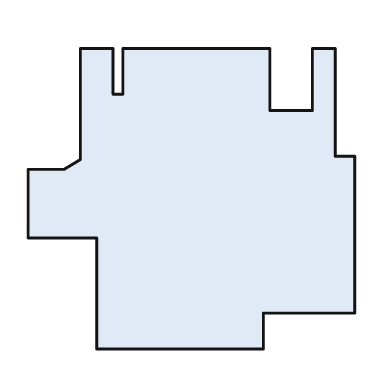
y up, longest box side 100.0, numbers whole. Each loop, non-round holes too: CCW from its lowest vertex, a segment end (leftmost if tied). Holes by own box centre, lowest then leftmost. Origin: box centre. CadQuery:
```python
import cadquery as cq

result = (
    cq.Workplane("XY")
    .moveTo(-29.0, -46.0)
    .lineTo(22.0, -46.0)
    .lineTo(22.0, -35.0)
    .lineTo(50.0, -35.0)
    .lineTo(50.0, 13.0)
    .lineTo(44.0, 13.0)
    .lineTo(44.0, 46.0)
    .lineTo(37.0, 46.0)
    .lineTo(37.0, 27.0)
    .lineTo(24.0, 27.0)
    .lineTo(24.0, 46.0)
    .lineTo(-21.0, 46.0)
    .lineTo(-21.0, 32.0)
    .lineTo(-24.0, 32.0)
    .lineTo(-24.0, 46.0)
    .lineTo(-34.0, 46.0)
    .lineTo(-34.0, 12.0)
    .lineTo(-39.0, 9.0)
    .lineTo(-50.0, 9.0)
    .lineTo(-50.0, -12.0)
    .lineTo(-29.0, -12.0)
    .close()
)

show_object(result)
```